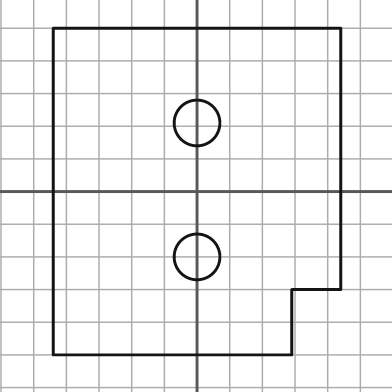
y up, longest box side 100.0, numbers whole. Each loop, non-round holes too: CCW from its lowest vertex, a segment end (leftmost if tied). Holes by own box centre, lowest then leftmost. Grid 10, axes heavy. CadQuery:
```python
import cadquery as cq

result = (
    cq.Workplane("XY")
    .moveTo(-44.0, -50.0)
    .lineTo(29.0, -50.0)
    .lineTo(29.0, -30.0)
    .lineTo(44.0, -30.0)
    .lineTo(44.0, 50.0)
    .lineTo(-44.0, 50.0)
    .close()
    .moveTo(0.0, -20.0)
    .circle(7.0)
    .moveTo(0.0, 21.0)
    .circle(7.0)
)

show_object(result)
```